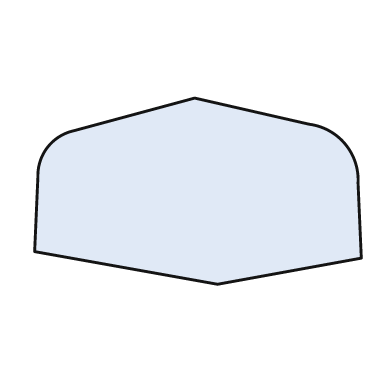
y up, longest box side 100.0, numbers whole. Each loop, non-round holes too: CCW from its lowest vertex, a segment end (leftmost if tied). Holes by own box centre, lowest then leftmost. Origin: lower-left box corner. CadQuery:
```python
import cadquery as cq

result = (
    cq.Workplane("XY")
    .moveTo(56.0, 0.0)
    .lineTo(100.0, 8.0)
    .lineTo(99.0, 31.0)
    .threePointArc((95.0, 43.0), (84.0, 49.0))
    .lineTo(49.0, 57.0)
    .lineTo(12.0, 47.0)
    .threePointArc((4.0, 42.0), (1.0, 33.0))
    .lineTo(0.0, 10.0)
    .close()
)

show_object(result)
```